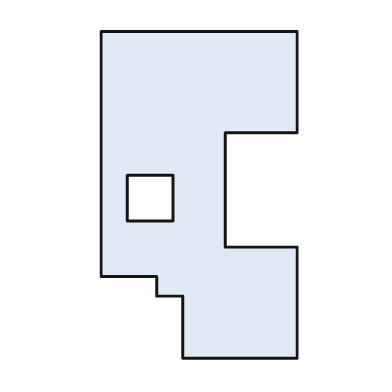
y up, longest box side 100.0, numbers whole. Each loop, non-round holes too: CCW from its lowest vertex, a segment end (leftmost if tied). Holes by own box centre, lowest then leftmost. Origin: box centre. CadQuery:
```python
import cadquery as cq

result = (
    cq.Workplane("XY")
    .moveTo(-5.0, -50.0)
    .lineTo(30.0, -50.0)
    .lineTo(30.0, -16.0)
    .lineTo(8.0, -16.0)
    .lineTo(8.0, 19.0)
    .lineTo(30.0, 19.0)
    .lineTo(30.0, 50.0)
    .lineTo(-30.0, 50.0)
    .lineTo(-30.0, -25.0)
    .lineTo(-13.0, -25.0)
    .lineTo(-13.0, -31.0)
    .lineTo(-5.0, -31.0)
    .close()
    .moveTo(-22.0, -8.0)
    .lineTo(-8.0, -8.0)
    .lineTo(-8.0, 6.0)
    .lineTo(-22.0, 6.0)
    .close()
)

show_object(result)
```